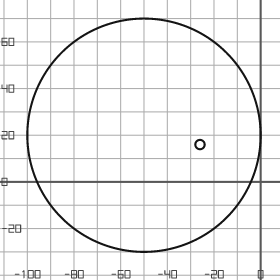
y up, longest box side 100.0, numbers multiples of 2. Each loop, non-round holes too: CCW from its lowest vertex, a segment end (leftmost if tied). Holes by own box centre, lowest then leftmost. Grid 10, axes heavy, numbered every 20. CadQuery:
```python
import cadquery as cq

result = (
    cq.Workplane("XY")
    .moveTo(-50.0, 20.0)
    .circle(50.0)
    .moveTo(-26.0, 16.0)
    .circle(2.0)
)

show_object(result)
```